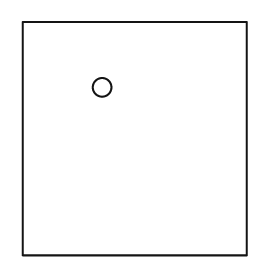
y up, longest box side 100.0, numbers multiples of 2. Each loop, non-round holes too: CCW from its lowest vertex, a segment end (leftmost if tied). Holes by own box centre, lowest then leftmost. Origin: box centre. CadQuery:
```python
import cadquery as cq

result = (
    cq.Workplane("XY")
    .moveTo(-48.0, -50.0)
    .lineTo(48.0, -50.0)
    .lineTo(48.0, 50.0)
    .lineTo(-48.0, 50.0)
    .close()
    .moveTo(-14.0, 22.0)
    .circle(4.0)
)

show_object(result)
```